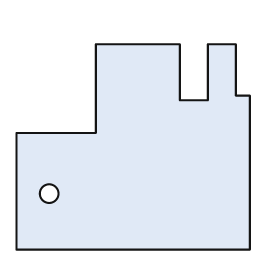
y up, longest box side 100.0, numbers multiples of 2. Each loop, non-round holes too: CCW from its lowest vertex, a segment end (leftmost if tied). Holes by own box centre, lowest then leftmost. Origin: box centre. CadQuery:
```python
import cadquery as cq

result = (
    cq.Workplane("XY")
    .moveTo(-50.0, -44.0)
    .lineTo(50.0, -44.0)
    .lineTo(50.0, 22.0)
    .lineTo(44.0, 22.0)
    .lineTo(44.0, 44.0)
    .lineTo(32.0, 44.0)
    .lineTo(32.0, 20.0)
    .lineTo(20.0, 20.0)
    .lineTo(20.0, 44.0)
    .lineTo(-16.0, 44.0)
    .lineTo(-16.0, 6.0)
    .lineTo(-50.0, 6.0)
    .close()
    .moveTo(-36.0, -20.0)
    .circle(4.0)
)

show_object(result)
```